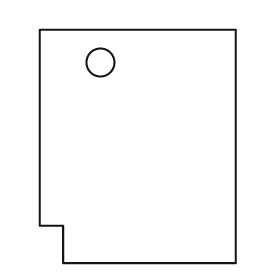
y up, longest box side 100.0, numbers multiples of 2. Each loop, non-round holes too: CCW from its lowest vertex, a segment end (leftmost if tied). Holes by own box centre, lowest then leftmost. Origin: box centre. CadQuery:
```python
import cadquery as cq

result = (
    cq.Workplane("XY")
    .moveTo(-32.0, -50.0)
    .lineTo(42.0, -50.0)
    .lineTo(42.0, 50.0)
    .lineTo(-42.0, 50.0)
    .lineTo(-42.0, -34.0)
    .lineTo(-32.0, -34.0)
    .close()
    .moveTo(-16.0, 36.0)
    .circle(6.0)
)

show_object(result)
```